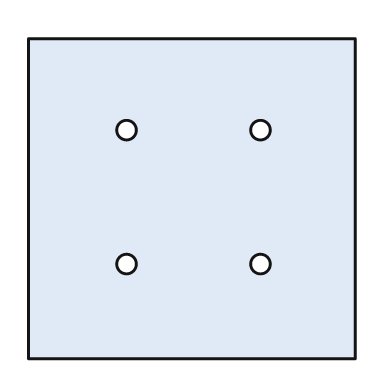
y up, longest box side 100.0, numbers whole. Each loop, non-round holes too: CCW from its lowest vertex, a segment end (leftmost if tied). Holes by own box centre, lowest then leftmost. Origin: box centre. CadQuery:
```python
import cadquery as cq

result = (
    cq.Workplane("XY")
    .moveTo(-50.0, -49.0)
    .lineTo(50.0, -49.0)
    .lineTo(50.0, 49.0)
    .lineTo(-50.0, 49.0)
    .close()
    .moveTo(-20.0, -20.0)
    .circle(3.0)
    .moveTo(21.0, -20.0)
    .circle(3.0)
    .moveTo(-20.0, 21.0)
    .circle(3.0)
    .moveTo(21.0, 21.0)
    .circle(3.0)
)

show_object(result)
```